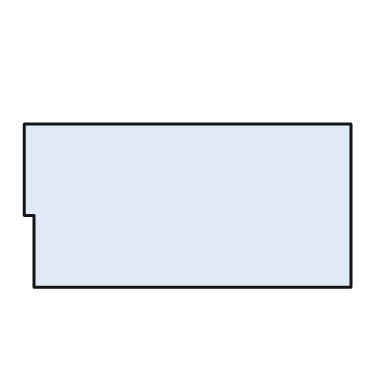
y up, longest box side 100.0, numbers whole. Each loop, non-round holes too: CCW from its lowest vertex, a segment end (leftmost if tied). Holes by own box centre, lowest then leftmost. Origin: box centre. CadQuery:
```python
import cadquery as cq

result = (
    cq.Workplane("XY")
    .moveTo(-47.0, -25.0)
    .lineTo(50.0, -25.0)
    .lineTo(50.0, 25.0)
    .lineTo(-50.0, 25.0)
    .lineTo(-50.0, -3.0)
    .lineTo(-47.0, -3.0)
    .close()
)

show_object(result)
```